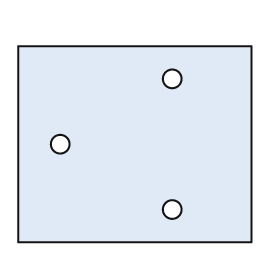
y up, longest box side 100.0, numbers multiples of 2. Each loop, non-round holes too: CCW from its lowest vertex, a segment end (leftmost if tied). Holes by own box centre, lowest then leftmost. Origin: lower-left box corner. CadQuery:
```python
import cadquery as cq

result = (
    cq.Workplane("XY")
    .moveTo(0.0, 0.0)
    .lineTo(100.0, 0.0)
    .lineTo(100.0, 84.0)
    .lineTo(0.0, 84.0)
    .close()
    .moveTo(66.0, 14.0)
    .circle(4.0)
    .moveTo(18.0, 42.0)
    .circle(4.0)
    .moveTo(66.0, 70.0)
    .circle(4.0)
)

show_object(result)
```